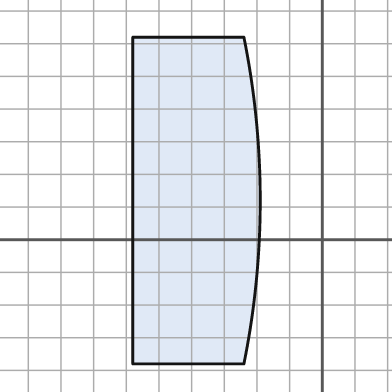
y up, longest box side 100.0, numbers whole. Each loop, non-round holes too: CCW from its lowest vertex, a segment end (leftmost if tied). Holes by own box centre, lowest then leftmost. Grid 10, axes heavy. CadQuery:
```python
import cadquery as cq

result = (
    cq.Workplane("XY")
    .moveTo(-58.0, -38.0)
    .lineTo(-24.0, -38.0)
    .threePointArc((-19.0, 12.0), (-24.0, 62.0))
    .lineTo(-58.0, 62.0)
    .close()
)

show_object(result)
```